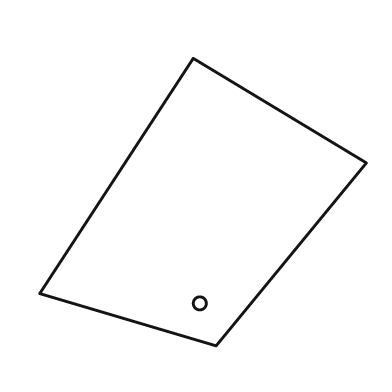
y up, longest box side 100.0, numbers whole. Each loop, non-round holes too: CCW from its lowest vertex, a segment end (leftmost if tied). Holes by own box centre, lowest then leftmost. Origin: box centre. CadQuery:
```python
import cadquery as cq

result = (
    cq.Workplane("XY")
    .moveTo(4.0, -44.0)
    .lineTo(50.0, 12.0)
    .lineTo(-3.0, 44.0)
    .lineTo(-50.0, -28.0)
    .close()
    .moveTo(-1.0, -31.0)
    .circle(2.0)
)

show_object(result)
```